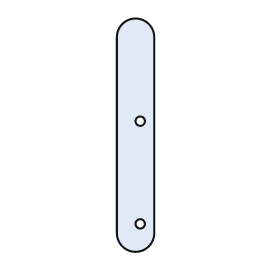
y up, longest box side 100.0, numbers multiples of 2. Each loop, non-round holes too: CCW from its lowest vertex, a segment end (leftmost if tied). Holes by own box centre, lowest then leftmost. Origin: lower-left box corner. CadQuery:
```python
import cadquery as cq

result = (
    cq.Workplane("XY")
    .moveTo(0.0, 8.0)
    .threePointArc((8.0, 0.0), (16.0, 8.0))
    .lineTo(16.0, 92.0)
    .threePointArc((8.0, 100.0), (0.0, 92.0))
    .close()
    .moveTo(10.0, 12.0)
    .circle(2.0)
    .moveTo(10.0, 56.0)
    .circle(2.0)
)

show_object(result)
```